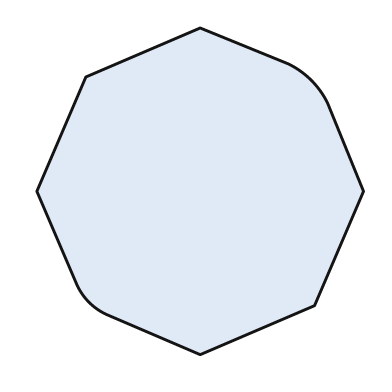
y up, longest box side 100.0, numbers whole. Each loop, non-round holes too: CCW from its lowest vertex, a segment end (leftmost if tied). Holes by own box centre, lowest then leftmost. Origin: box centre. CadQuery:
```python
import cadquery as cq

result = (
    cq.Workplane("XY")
    .moveTo(0.0, -50.0)
    .lineTo(35.0, -35.0)
    .lineTo(50.0, 0.0)
    .lineTo(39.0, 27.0)
    .threePointArc((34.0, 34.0), (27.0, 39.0))
    .lineTo(0.0, 50.0)
    .lineTo(-35.0, 35.0)
    .lineTo(-50.0, 0.0)
    .lineTo(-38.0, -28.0)
    .threePointArc((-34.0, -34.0), (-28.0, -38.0))
    .close()
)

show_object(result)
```